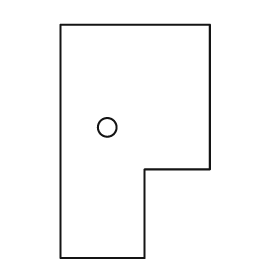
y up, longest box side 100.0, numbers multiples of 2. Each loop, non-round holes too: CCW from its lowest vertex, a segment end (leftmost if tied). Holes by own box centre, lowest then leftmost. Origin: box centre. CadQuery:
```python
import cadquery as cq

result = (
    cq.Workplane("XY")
    .moveTo(-32.0, -50.0)
    .lineTo(4.0, -50.0)
    .lineTo(4.0, -12.0)
    .lineTo(32.0, -12.0)
    .lineTo(32.0, 50.0)
    .lineTo(-32.0, 50.0)
    .close()
    .moveTo(-12.0, 6.0)
    .circle(4.0)
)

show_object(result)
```